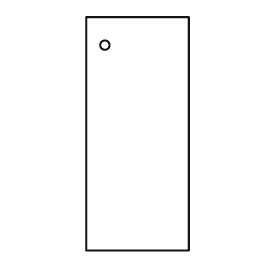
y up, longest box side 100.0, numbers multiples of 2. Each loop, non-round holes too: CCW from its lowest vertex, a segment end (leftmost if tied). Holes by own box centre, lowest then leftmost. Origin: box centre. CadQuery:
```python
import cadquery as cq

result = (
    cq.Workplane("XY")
    .moveTo(-22.0, -50.0)
    .lineTo(22.0, -50.0)
    .lineTo(22.0, 50.0)
    .lineTo(-22.0, 50.0)
    .close()
    .moveTo(-14.0, 38.0)
    .circle(2.0)
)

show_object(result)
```